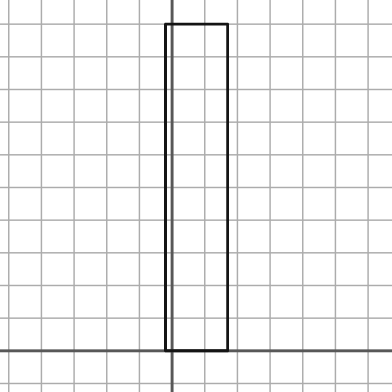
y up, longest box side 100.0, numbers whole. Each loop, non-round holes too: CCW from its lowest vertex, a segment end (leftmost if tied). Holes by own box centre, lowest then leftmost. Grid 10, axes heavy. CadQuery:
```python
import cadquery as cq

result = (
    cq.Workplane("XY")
    .moveTo(-2.0, 0.0)
    .lineTo(17.0, 0.0)
    .lineTo(17.0, 100.0)
    .lineTo(-2.0, 100.0)
    .close()
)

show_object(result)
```